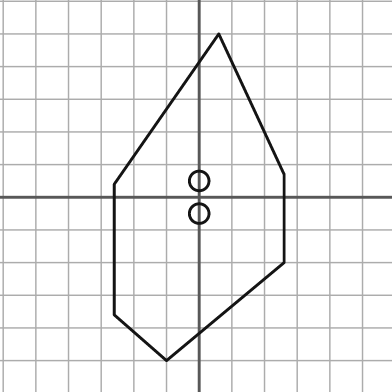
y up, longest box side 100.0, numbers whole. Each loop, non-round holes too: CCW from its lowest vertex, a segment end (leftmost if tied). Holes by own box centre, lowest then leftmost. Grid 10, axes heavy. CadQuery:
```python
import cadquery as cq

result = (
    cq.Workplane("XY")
    .moveTo(-10.0, -50.0)
    .lineTo(26.0, -20.0)
    .lineTo(26.0, 7.0)
    .lineTo(6.0, 50.0)
    .lineTo(-26.0, 4.0)
    .lineTo(-26.0, -36.0)
    .close()
    .moveTo(0.0, -5.0)
    .circle(3.0)
    .moveTo(0.0, 5.0)
    .circle(3.0)
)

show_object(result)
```